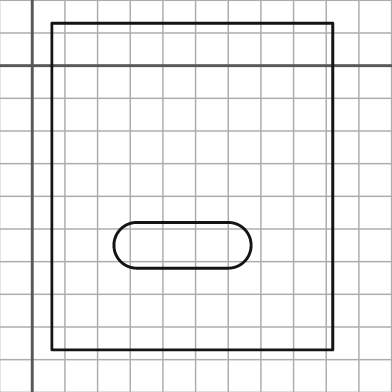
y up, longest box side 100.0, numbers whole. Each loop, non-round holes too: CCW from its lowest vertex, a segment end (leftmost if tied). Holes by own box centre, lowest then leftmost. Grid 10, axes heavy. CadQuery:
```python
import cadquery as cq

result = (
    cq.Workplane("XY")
    .moveTo(6.0, -87.0)
    .lineTo(92.0, -87.0)
    .lineTo(92.0, 13.0)
    .lineTo(6.0, 13.0)
    .close()
    .moveTo(32.0, -62.0)
    .lineTo(60.0, -62.0)
    .threePointArc((67.0, -55.0), (60.0, -48.0))
    .lineTo(32.0, -48.0)
    .threePointArc((25.0, -55.0), (32.0, -62.0))
    .close()
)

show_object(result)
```